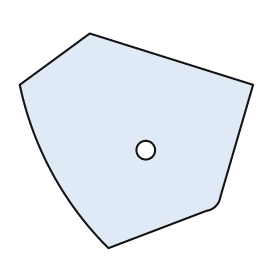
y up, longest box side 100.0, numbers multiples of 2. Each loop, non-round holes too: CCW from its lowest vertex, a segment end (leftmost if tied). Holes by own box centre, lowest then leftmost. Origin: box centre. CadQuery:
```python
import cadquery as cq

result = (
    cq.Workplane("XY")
    .moveTo(-12.0, -46.0)
    .lineTo(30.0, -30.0)
    .threePointArc((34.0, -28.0), (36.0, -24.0))
    .lineTo(50.0, 24.0)
    .lineTo(-20.0, 46.0)
    .lineTo(-50.0, 24.0)
    .threePointArc((-36.0, -14.0), (-12.0, -46.0))
    .close()
    .moveTo(4.0, -4.0)
    .circle(4.0)
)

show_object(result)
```